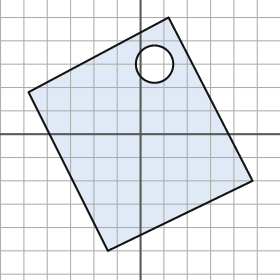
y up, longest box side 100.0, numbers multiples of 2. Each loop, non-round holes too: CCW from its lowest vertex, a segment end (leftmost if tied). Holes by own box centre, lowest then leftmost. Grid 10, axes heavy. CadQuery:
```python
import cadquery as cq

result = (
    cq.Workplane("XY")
    .moveTo(-14.0, -50.0)
    .lineTo(48.0, -20.0)
    .lineTo(12.0, 50.0)
    .lineTo(-48.0, 18.0)
    .close()
    .moveTo(6.0, 30.0)
    .circle(8.0)
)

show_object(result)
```